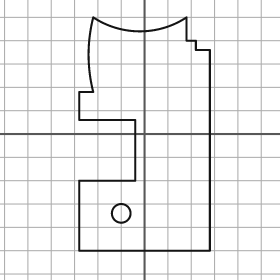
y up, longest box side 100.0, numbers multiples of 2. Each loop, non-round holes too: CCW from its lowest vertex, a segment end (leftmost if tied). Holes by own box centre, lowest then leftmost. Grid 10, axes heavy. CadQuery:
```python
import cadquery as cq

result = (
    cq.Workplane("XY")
    .moveTo(-28.0, -50.0)
    .lineTo(28.0, -50.0)
    .lineTo(28.0, 36.0)
    .lineTo(22.0, 36.0)
    .lineTo(22.0, 40.0)
    .lineTo(18.0, 40.0)
    .lineTo(18.0, 50.0)
    .threePointArc((-2.0, 44.0), (-22.0, 50.0))
    .threePointArc((-24.0, 34.0), (-22.0, 18.0))
    .lineTo(-28.0, 18.0)
    .lineTo(-28.0, 6.0)
    .lineTo(-4.0, 6.0)
    .lineTo(-4.0, -20.0)
    .lineTo(-28.0, -20.0)
    .close()
    .moveTo(-10.0, -34.0)
    .circle(4.0)
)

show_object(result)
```